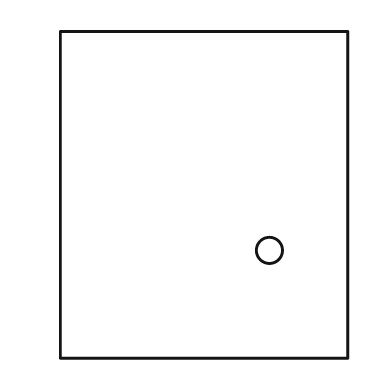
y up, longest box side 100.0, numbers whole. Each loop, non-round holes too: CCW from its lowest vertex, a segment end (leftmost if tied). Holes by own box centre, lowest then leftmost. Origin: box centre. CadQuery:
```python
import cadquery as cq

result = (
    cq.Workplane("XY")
    .moveTo(-44.0, -50.0)
    .lineTo(44.0, -50.0)
    .lineTo(44.0, 50.0)
    .lineTo(-44.0, 50.0)
    .close()
    .moveTo(20.0, -17.0)
    .circle(4.0)
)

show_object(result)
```